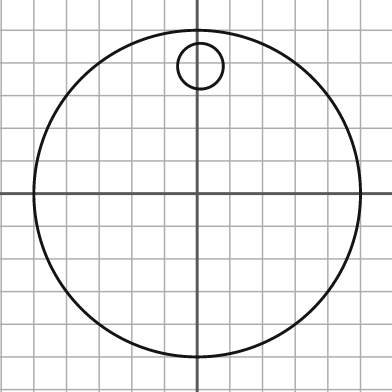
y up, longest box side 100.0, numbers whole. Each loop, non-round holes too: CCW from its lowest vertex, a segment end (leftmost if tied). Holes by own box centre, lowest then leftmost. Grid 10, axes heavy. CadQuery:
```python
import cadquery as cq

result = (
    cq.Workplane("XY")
    .moveTo(0.0, 0.0)
    .circle(50.0)
    .moveTo(1.0, 39.0)
    .circle(7.0)
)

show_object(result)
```